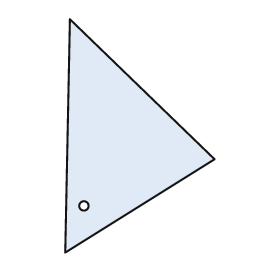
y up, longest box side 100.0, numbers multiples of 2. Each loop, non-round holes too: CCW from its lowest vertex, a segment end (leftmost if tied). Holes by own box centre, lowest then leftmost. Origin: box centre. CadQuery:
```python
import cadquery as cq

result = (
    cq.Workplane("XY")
    .moveTo(-32.0, -50.0)
    .lineTo(32.0, -10.0)
    .lineTo(-30.0, 50.0)
    .close()
    .moveTo(-24.0, -30.0)
    .circle(2.0)
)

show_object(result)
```